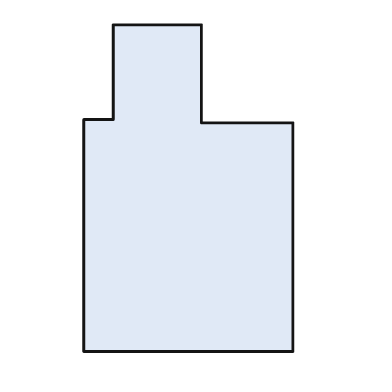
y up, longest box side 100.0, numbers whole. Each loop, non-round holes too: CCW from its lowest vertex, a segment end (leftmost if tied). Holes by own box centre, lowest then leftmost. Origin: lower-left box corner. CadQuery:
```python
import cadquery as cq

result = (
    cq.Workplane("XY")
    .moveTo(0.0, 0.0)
    .lineTo(64.0, 0.0)
    .lineTo(64.0, 70.0)
    .lineTo(36.0, 70.0)
    .lineTo(36.0, 100.0)
    .lineTo(9.0, 100.0)
    .lineTo(9.0, 71.0)
    .lineTo(0.0, 71.0)
    .close()
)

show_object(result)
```